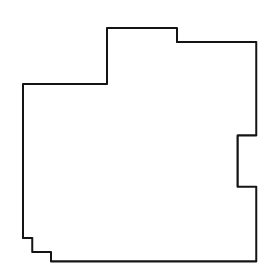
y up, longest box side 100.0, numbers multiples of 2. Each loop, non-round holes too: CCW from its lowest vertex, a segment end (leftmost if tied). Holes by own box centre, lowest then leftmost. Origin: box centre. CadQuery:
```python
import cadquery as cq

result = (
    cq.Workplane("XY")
    .moveTo(-38.0, -50.0)
    .lineTo(50.0, -50.0)
    .lineTo(50.0, -18.0)
    .lineTo(42.0, -18.0)
    .lineTo(42.0, 4.0)
    .lineTo(50.0, 4.0)
    .lineTo(50.0, 44.0)
    .lineTo(16.0, 44.0)
    .lineTo(16.0, 50.0)
    .lineTo(-14.0, 50.0)
    .lineTo(-14.0, 26.0)
    .lineTo(-50.0, 26.0)
    .lineTo(-50.0, -40.0)
    .lineTo(-46.0, -40.0)
    .lineTo(-46.0, -46.0)
    .lineTo(-38.0, -46.0)
    .close()
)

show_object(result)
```